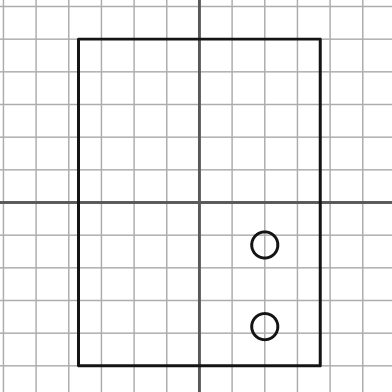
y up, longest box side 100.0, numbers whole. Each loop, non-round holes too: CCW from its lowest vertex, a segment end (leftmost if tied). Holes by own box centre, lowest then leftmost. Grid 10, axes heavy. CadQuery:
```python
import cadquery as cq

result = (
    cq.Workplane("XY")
    .moveTo(-37.0, -50.0)
    .lineTo(37.0, -50.0)
    .lineTo(37.0, 50.0)
    .lineTo(-37.0, 50.0)
    .close()
    .moveTo(20.0, -38.0)
    .circle(4.0)
    .moveTo(20.0, -13.0)
    .circle(4.0)
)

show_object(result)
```